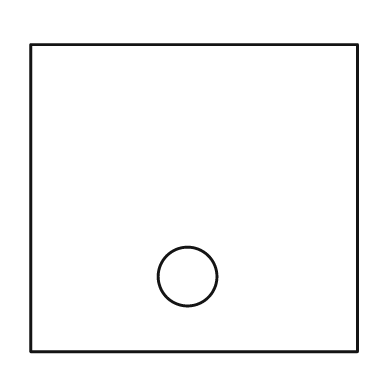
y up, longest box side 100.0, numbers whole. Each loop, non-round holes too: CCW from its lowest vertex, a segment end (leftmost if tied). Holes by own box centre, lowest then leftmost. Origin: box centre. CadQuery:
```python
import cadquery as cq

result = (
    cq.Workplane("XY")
    .moveTo(-50.0, -47.0)
    .lineTo(50.0, -47.0)
    .lineTo(50.0, 47.0)
    .lineTo(-50.0, 47.0)
    .close()
    .moveTo(-2.0, -24.0)
    .circle(9.0)
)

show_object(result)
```